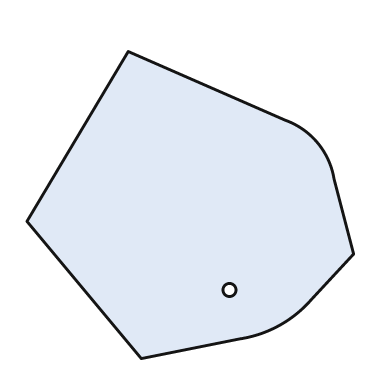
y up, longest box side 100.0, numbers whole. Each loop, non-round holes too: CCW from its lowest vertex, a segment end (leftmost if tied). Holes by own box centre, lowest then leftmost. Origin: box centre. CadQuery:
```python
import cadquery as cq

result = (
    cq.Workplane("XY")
    .moveTo(-15.0, -47.0)
    .lineTo(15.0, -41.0)
    .threePointArc((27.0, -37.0), (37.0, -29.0))
    .lineTo(50.0, -15.0)
    .lineTo(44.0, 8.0)
    .threePointArc((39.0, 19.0), (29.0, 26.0))
    .lineTo(-19.0, 47.0)
    .lineTo(-50.0, -5.0)
    .close()
    .moveTo(12.0, -26.0)
    .circle(2.0)
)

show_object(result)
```